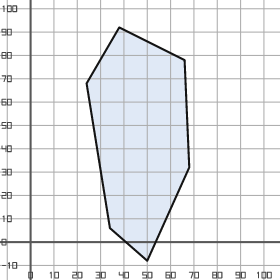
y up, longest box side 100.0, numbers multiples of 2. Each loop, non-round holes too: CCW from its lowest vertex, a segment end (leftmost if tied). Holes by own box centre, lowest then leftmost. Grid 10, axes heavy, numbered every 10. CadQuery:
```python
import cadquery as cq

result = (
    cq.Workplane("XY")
    .moveTo(50.0, -8.0)
    .lineTo(68.0, 32.0)
    .lineTo(66.0, 78.0)
    .lineTo(38.0, 92.0)
    .lineTo(24.0, 68.0)
    .lineTo(34.0, 6.0)
    .close()
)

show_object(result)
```